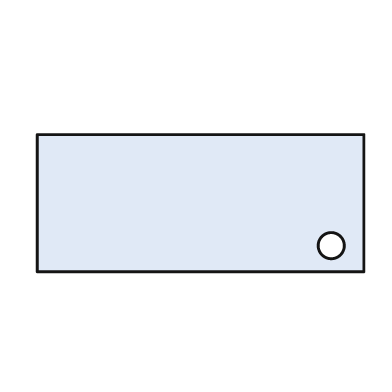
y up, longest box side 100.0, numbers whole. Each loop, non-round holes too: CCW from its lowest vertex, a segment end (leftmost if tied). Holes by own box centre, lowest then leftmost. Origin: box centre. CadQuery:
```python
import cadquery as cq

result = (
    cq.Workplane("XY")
    .moveTo(-50.0, -21.0)
    .lineTo(50.0, -21.0)
    .lineTo(50.0, 21.0)
    .lineTo(-50.0, 21.0)
    .close()
    .moveTo(40.0, -13.0)
    .circle(4.0)
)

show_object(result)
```